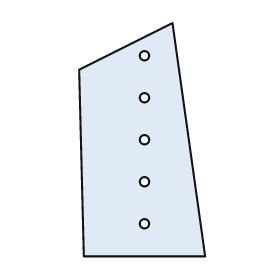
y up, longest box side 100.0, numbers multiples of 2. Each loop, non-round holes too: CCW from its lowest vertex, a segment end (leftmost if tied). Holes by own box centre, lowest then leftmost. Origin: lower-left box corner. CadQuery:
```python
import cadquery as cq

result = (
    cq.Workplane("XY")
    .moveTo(2.0, 0.0)
    .lineTo(54.0, 0.0)
    .lineTo(40.0, 100.0)
    .lineTo(0.0, 80.0)
    .close()
    .moveTo(28.0, 14.0)
    .circle(2.0)
    .moveTo(28.0, 32.0)
    .circle(2.0)
    .moveTo(28.0, 50.0)
    .circle(2.0)
    .moveTo(28.0, 68.0)
    .circle(2.0)
    .moveTo(28.0, 86.0)
    .circle(2.0)
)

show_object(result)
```